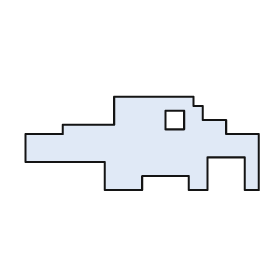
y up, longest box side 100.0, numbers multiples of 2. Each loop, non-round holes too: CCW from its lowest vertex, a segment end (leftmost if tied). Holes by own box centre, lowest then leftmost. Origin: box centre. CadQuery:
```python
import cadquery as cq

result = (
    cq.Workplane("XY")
    .moveTo(-16.0, -20.0)
    .lineTo(0.0, -20.0)
    .lineTo(0.0, -14.0)
    .lineTo(20.0, -14.0)
    .lineTo(20.0, -20.0)
    .lineTo(28.0, -20.0)
    .lineTo(28.0, -6.0)
    .lineTo(44.0, -6.0)
    .lineTo(44.0, -20.0)
    .lineTo(50.0, -20.0)
    .lineTo(50.0, 4.0)
    .lineTo(36.0, 4.0)
    .lineTo(36.0, 10.0)
    .lineTo(26.0, 10.0)
    .lineTo(26.0, 16.0)
    .lineTo(22.0, 16.0)
    .lineTo(22.0, 20.0)
    .lineTo(-12.0, 20.0)
    .lineTo(-12.0, 8.0)
    .lineTo(-34.0, 8.0)
    .lineTo(-34.0, 4.0)
    .lineTo(-50.0, 4.0)
    .lineTo(-50.0, -8.0)
    .lineTo(-16.0, -8.0)
    .close()
    .moveTo(10.0, 6.0)
    .lineTo(18.0, 6.0)
    .lineTo(18.0, 14.0)
    .lineTo(10.0, 14.0)
    .close()
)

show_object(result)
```